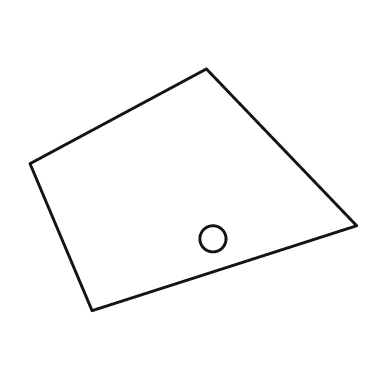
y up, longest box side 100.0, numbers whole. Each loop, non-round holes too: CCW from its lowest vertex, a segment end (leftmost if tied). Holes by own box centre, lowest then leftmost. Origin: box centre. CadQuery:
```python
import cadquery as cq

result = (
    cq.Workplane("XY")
    .moveTo(-31.0, -37.0)
    .lineTo(50.0, -11.0)
    .lineTo(4.0, 37.0)
    .lineTo(-50.0, 8.0)
    .close()
    .moveTo(6.0, -15.0)
    .circle(4.0)
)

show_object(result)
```